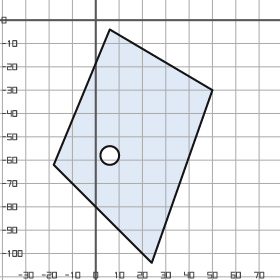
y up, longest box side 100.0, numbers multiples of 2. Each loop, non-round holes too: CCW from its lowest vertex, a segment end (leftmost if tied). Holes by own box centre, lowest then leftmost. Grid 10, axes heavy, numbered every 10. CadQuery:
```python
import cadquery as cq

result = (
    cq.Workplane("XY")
    .moveTo(24.0, -104.0)
    .lineTo(50.0, -30.0)
    .lineTo(6.0, -4.0)
    .lineTo(-18.0, -62.0)
    .close()
    .moveTo(6.0, -58.0)
    .circle(4.0)
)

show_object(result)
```